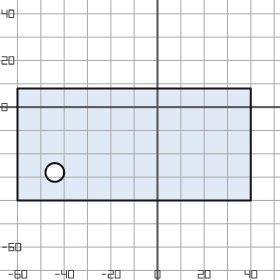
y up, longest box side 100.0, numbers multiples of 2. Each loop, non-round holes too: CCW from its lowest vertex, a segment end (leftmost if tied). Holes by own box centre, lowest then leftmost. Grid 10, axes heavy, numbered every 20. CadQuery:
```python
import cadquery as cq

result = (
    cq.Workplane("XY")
    .moveTo(-60.0, -40.0)
    .lineTo(40.0, -40.0)
    .lineTo(40.0, 8.0)
    .lineTo(-60.0, 8.0)
    .close()
    .moveTo(-44.0, -28.0)
    .circle(4.0)
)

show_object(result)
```